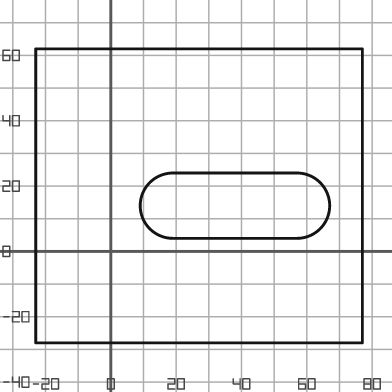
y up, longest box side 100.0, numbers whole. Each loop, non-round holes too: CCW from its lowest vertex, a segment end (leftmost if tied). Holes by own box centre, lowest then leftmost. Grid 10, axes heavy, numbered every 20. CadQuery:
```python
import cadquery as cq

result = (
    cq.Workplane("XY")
    .moveTo(-23.0, -28.0)
    .lineTo(77.0, -28.0)
    .lineTo(77.0, 62.0)
    .lineTo(-23.0, 62.0)
    .close()
    .moveTo(19.0, 4.0)
    .lineTo(57.0, 4.0)
    .threePointArc((67.0, 14.0), (57.0, 24.0))
    .lineTo(19.0, 24.0)
    .threePointArc((9.0, 14.0), (19.0, 4.0))
    .close()
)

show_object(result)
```